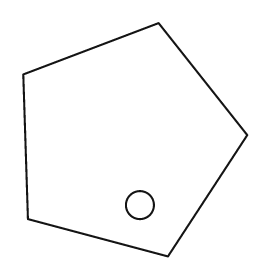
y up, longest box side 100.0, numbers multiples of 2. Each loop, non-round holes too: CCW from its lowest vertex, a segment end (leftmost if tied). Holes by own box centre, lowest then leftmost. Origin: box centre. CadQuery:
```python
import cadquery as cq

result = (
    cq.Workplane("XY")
    .moveTo(14.0, -50.0)
    .lineTo(48.0, 2.0)
    .lineTo(10.0, 50.0)
    .lineTo(-48.0, 28.0)
    .lineTo(-46.0, -34.0)
    .close()
    .moveTo(2.0, -28.0)
    .circle(6.0)
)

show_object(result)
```